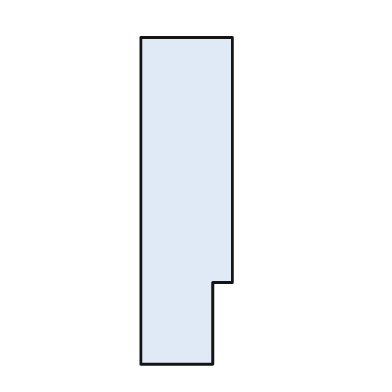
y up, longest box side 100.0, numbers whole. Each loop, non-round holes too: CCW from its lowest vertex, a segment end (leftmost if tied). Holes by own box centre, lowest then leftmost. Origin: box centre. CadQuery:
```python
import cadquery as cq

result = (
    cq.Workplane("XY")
    .moveTo(-14.0, -50.0)
    .lineTo(8.0, -50.0)
    .lineTo(8.0, -25.0)
    .lineTo(14.0, -25.0)
    .lineTo(14.0, 50.0)
    .lineTo(-14.0, 50.0)
    .close()
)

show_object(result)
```